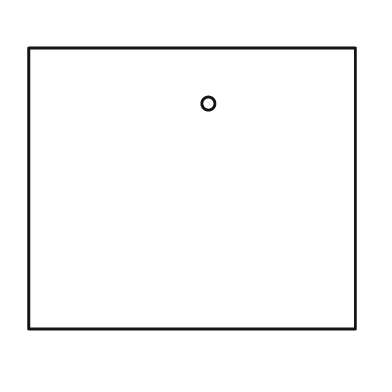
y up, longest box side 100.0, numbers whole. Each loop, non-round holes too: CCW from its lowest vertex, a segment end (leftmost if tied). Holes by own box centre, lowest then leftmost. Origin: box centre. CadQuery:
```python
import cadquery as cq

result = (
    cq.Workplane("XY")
    .moveTo(-50.0, -43.0)
    .lineTo(50.0, -43.0)
    .lineTo(50.0, 43.0)
    .lineTo(-50.0, 43.0)
    .close()
    .moveTo(5.0, 26.0)
    .circle(2.0)
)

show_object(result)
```